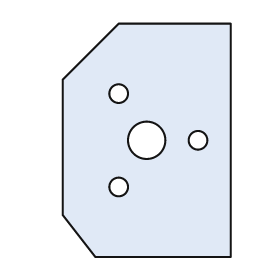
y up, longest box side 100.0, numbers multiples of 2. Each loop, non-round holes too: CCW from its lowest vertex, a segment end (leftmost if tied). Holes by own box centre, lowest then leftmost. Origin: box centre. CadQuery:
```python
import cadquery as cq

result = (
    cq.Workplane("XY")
    .moveTo(-22.0, -50.0)
    .lineTo(36.0, -50.0)
    .lineTo(36.0, 50.0)
    .lineTo(-12.0, 50.0)
    .lineTo(-36.0, 26.0)
    .lineTo(-36.0, -32.0)
    .close()
    .moveTo(-12.0, -20.0)
    .circle(4.0)
    .moveTo(0.0, 0.0)
    .circle(8.0)
    .moveTo(22.0, 0.0)
    .circle(4.0)
    .moveTo(-12.0, 20.0)
    .circle(4.0)
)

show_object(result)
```